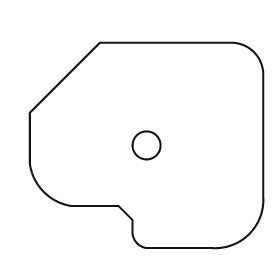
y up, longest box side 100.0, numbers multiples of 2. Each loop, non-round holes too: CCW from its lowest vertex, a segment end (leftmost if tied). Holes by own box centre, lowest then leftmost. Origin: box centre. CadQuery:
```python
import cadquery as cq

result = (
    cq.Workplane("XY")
    .moveTo(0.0, -44.0)
    .lineTo(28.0, -44.0)
    .threePointArc((44.0, -38.0), (50.0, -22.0))
    .lineTo(50.0, 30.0)
    .threePointArc((46.0, 40.0), (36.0, 44.0))
    .lineTo(-20.0, 44.0)
    .lineTo(-50.0, 14.0)
    .lineTo(-50.0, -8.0)
    .threePointArc((-44.0, -20.0), (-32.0, -26.0))
    .lineTo(-12.0, -26.0)
    .lineTo(-6.0, -32.0)
    .lineTo(-6.0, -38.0)
    .threePointArc((-4.0, -42.0), (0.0, -44.0))
    .close()
    .moveTo(0.0, 0.0)
    .circle(6.0)
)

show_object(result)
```